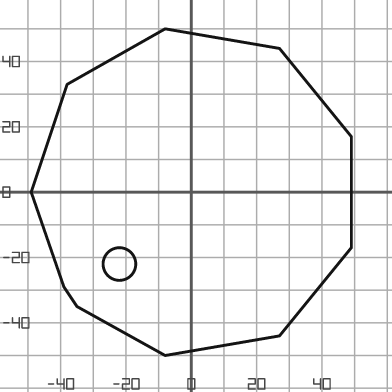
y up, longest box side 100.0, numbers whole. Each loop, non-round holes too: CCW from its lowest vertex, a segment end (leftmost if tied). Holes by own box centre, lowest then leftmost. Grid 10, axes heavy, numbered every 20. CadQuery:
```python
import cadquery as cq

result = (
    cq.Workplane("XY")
    .moveTo(-8.0, -50.0)
    .lineTo(27.0, -44.0)
    .lineTo(49.0, -17.0)
    .lineTo(49.0, 17.0)
    .lineTo(27.0, 44.0)
    .lineTo(-8.0, 50.0)
    .lineTo(-38.0, 33.0)
    .lineTo(-49.0, 0.0)
    .lineTo(-39.0, -29.0)
    .lineTo(-35.0, -35.0)
    .close()
    .moveTo(-22.0, -22.0)
    .circle(5.0)
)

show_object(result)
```